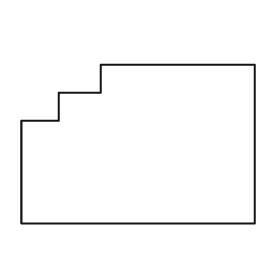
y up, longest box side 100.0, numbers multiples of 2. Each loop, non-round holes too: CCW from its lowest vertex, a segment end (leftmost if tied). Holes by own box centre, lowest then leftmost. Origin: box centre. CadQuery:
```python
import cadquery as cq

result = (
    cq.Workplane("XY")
    .moveTo(-50.0, -34.0)
    .lineTo(50.0, -34.0)
    .lineTo(50.0, 34.0)
    .lineTo(-16.0, 34.0)
    .lineTo(-16.0, 22.0)
    .lineTo(-34.0, 22.0)
    .lineTo(-34.0, 10.0)
    .lineTo(-50.0, 10.0)
    .close()
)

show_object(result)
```